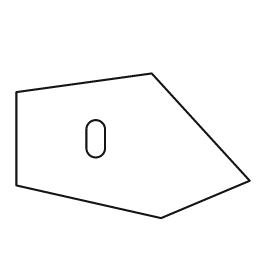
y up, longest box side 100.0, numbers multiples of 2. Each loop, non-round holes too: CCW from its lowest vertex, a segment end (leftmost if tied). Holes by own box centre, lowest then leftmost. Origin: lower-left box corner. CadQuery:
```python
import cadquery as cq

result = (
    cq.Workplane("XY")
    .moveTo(62.0, 0.0)
    .lineTo(100.0, 16.0)
    .lineTo(58.0, 62.0)
    .lineTo(0.0, 54.0)
    .lineTo(0.0, 14.0)
    .close()
    .moveTo(30.0, 30.0)
    .threePointArc((34.0, 26.0), (38.0, 30.0))
    .lineTo(38.0, 38.0)
    .threePointArc((34.0, 42.0), (30.0, 38.0))
    .close()
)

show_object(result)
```